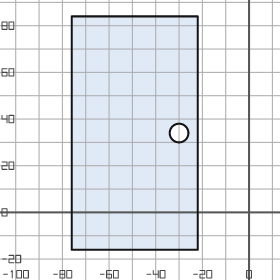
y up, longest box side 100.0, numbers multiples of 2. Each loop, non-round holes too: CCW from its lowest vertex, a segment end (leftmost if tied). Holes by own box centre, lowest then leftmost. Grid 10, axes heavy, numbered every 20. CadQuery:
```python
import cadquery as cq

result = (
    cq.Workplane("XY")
    .moveTo(-76.0, -16.0)
    .lineTo(-22.0, -16.0)
    .lineTo(-22.0, 84.0)
    .lineTo(-76.0, 84.0)
    .close()
    .moveTo(-30.0, 34.0)
    .circle(4.0)
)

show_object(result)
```